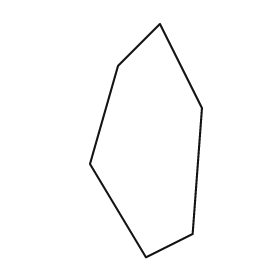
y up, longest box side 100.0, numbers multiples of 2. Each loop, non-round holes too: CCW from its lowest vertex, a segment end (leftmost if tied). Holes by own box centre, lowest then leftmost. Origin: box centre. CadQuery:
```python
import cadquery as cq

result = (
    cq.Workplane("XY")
    .moveTo(0.0, -50.0)
    .lineTo(20.0, -40.0)
    .lineTo(24.0, 14.0)
    .lineTo(6.0, 50.0)
    .lineTo(-12.0, 32.0)
    .lineTo(-24.0, -10.0)
    .close()
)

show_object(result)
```